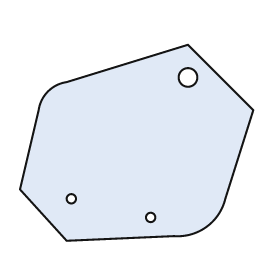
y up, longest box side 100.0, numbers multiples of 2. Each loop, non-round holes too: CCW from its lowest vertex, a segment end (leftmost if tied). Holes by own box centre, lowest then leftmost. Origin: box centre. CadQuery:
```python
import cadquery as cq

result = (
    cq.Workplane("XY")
    .moveTo(-30.0, -42.0)
    .lineTo(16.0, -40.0)
    .threePointArc((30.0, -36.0), (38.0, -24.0))
    .lineTo(50.0, 14.0)
    .lineTo(22.0, 42.0)
    .lineTo(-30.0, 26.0)
    .threePointArc((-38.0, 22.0), (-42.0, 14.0))
    .lineTo(-50.0, -20.0)
    .close()
    .moveTo(6.0, -32.0)
    .circle(2.0)
    .moveTo(-28.0, -24.0)
    .circle(2.0)
    .moveTo(22.0, 28.0)
    .circle(4.0)
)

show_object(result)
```